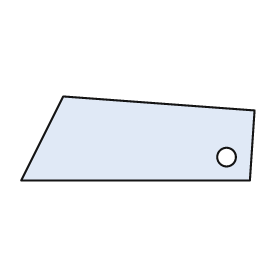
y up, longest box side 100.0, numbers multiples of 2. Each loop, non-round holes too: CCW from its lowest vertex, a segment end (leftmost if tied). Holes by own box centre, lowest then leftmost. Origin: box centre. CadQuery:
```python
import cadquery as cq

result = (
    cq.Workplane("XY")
    .moveTo(-50.0, -18.0)
    .lineTo(48.0, -18.0)
    .lineTo(50.0, 12.0)
    .lineTo(-32.0, 18.0)
    .close()
    .moveTo(38.0, -8.0)
    .circle(4.0)
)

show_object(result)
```